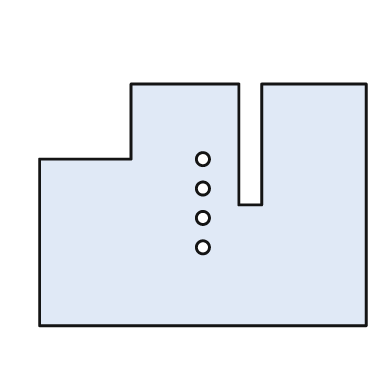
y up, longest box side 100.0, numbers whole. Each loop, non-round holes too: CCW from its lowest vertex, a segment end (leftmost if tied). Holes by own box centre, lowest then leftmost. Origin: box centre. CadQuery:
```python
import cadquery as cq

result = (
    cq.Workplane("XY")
    .moveTo(-50.0, -37.0)
    .lineTo(50.0, -37.0)
    .lineTo(50.0, 37.0)
    .lineTo(18.0, 37.0)
    .lineTo(18.0, 0.0)
    .lineTo(11.0, 0.0)
    .lineTo(11.0, 37.0)
    .lineTo(-22.0, 37.0)
    .lineTo(-22.0, 14.0)
    .lineTo(-50.0, 14.0)
    .close()
    .moveTo(0.0, -13.0)
    .circle(2.0)
    .moveTo(0.0, -4.0)
    .circle(2.0)
    .moveTo(0.0, 5.0)
    .circle(2.0)
    .moveTo(0.0, 14.0)
    .circle(2.0)
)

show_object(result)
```